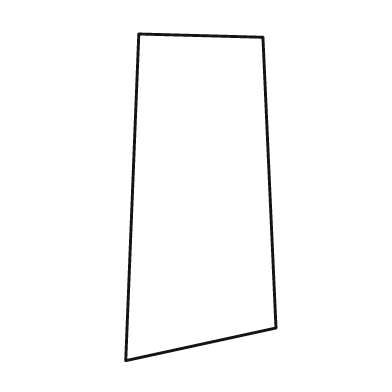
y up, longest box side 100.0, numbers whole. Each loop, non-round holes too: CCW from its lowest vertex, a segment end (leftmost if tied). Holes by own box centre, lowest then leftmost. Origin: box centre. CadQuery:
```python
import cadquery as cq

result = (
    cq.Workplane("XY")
    .moveTo(-23.0, -50.0)
    .lineTo(23.0, -40.0)
    .lineTo(19.0, 49.0)
    .lineTo(-19.0, 50.0)
    .close()
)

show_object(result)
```